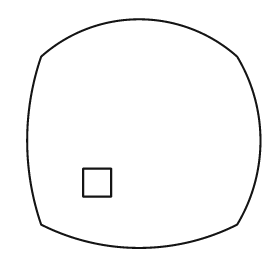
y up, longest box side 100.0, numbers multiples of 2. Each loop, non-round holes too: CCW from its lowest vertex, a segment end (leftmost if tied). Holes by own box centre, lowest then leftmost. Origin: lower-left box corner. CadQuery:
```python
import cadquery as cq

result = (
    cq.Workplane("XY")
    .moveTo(6.0, 10.0)
    .threePointArc((48.0, 0.0), (90.0, 10.0))
    .threePointArc((100.0, 46.0), (90.0, 82.0))
    .threePointArc((48.0, 98.0), (6.0, 82.0))
    .threePointArc((0.0, 46.0), (6.0, 10.0))
    .close()
    .moveTo(24.0, 22.0)
    .lineTo(36.0, 22.0)
    .lineTo(36.0, 34.0)
    .lineTo(24.0, 34.0)
    .close()
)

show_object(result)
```